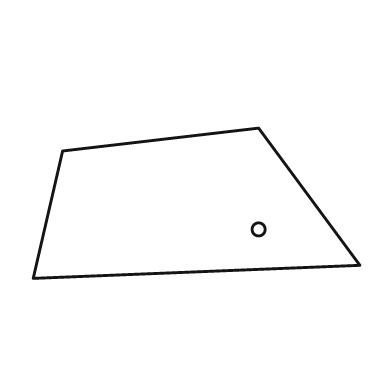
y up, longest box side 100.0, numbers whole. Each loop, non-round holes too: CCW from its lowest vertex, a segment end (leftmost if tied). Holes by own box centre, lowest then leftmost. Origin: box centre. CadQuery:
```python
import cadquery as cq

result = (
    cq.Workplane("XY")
    .moveTo(-50.0, -23.0)
    .lineTo(50.0, -19.0)
    .lineTo(19.0, 23.0)
    .lineTo(-41.0, 16.0)
    .close()
    .moveTo(19.0, -8.0)
    .circle(2.0)
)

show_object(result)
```